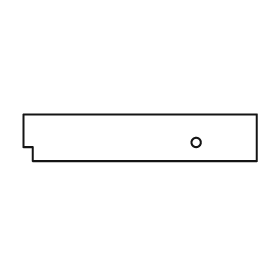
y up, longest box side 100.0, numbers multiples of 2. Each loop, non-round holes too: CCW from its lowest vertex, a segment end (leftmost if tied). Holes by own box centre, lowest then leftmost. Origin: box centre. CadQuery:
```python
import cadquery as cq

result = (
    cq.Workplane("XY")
    .moveTo(-46.0, -10.0)
    .lineTo(50.0, -10.0)
    .lineTo(50.0, 10.0)
    .lineTo(-50.0, 10.0)
    .lineTo(-50.0, -4.0)
    .lineTo(-46.0, -4.0)
    .close()
    .moveTo(24.0, -2.0)
    .circle(2.0)
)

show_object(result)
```